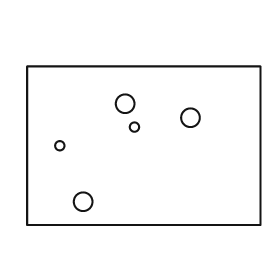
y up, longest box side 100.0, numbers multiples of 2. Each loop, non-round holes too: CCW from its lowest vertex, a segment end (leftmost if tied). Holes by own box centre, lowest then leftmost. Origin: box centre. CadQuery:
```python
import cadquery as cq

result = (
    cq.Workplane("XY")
    .moveTo(-50.0, -34.0)
    .lineTo(50.0, -34.0)
    .lineTo(50.0, 34.0)
    .lineTo(-50.0, 34.0)
    .close()
    .moveTo(-26.0, -24.0)
    .circle(4.0)
    .moveTo(-36.0, 0.0)
    .circle(2.0)
    .moveTo(-4.0, 8.0)
    .circle(2.0)
    .moveTo(20.0, 12.0)
    .circle(4.0)
    .moveTo(-8.0, 18.0)
    .circle(4.0)
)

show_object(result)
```